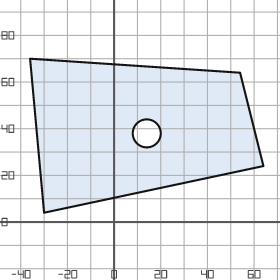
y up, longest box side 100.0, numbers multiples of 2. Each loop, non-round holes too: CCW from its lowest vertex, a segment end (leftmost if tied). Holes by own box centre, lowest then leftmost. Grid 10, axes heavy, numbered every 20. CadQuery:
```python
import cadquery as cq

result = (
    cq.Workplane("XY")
    .moveTo(-30.0, 4.0)
    .lineTo(64.0, 24.0)
    .lineTo(54.0, 64.0)
    .lineTo(-36.0, 70.0)
    .close()
    .moveTo(14.0, 38.0)
    .circle(6.0)
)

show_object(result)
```